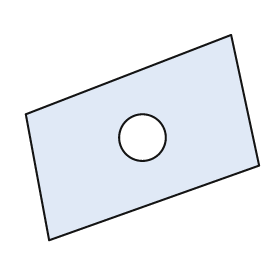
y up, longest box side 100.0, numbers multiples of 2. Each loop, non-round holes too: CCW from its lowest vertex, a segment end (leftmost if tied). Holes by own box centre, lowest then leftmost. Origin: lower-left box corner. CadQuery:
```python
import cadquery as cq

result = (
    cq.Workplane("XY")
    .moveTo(10.0, 0.0)
    .lineTo(100.0, 32.0)
    .lineTo(88.0, 88.0)
    .lineTo(0.0, 54.0)
    .close()
    .moveTo(50.0, 44.0)
    .circle(10.0)
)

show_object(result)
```